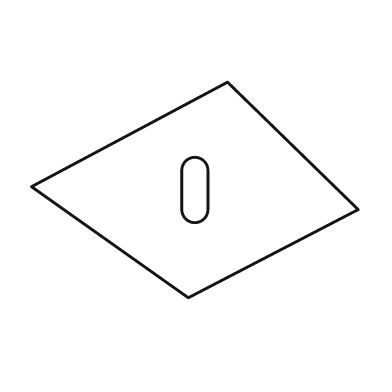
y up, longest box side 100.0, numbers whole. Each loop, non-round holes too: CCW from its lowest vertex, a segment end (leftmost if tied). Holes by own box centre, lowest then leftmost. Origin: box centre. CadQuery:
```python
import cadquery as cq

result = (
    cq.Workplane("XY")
    .moveTo(-2.0, -33.0)
    .lineTo(50.0, -6.0)
    .lineTo(10.0, 33.0)
    .lineTo(-50.0, 1.0)
    .close()
    .moveTo(-4.0, -6.0)
    .threePointArc((0.0, -10.0), (4.0, -6.0))
    .lineTo(4.0, 6.0)
    .threePointArc((0.0, 10.0), (-4.0, 6.0))
    .close()
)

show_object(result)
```